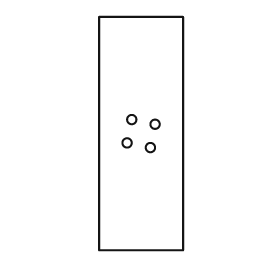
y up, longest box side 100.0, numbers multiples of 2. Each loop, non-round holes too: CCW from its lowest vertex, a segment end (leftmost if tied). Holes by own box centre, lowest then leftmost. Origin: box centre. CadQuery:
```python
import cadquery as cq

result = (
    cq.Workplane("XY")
    .moveTo(-18.0, -50.0)
    .lineTo(18.0, -50.0)
    .lineTo(18.0, 50.0)
    .lineTo(-18.0, 50.0)
    .close()
    .moveTo(4.0, -6.0)
    .circle(2.0)
    .moveTo(-6.0, -4.0)
    .circle(2.0)
    .moveTo(6.0, 4.0)
    .circle(2.0)
    .moveTo(-4.0, 6.0)
    .circle(2.0)
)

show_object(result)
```